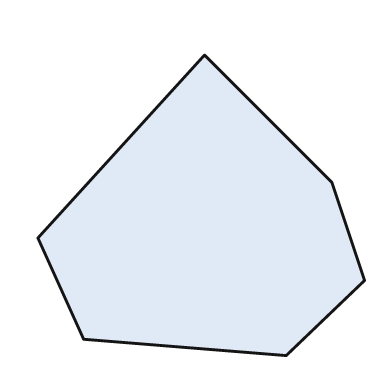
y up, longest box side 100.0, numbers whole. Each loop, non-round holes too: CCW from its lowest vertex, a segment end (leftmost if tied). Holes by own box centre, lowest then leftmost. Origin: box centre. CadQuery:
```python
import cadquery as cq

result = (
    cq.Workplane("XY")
    .moveTo(26.0, -46.0)
    .lineTo(50.0, -23.0)
    .lineTo(40.0, 7.0)
    .lineTo(1.0, 46.0)
    .lineTo(-50.0, -10.0)
    .lineTo(-36.0, -41.0)
    .close()
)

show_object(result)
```